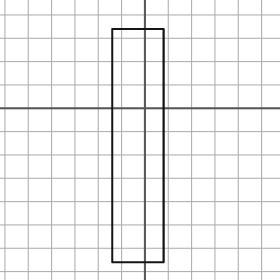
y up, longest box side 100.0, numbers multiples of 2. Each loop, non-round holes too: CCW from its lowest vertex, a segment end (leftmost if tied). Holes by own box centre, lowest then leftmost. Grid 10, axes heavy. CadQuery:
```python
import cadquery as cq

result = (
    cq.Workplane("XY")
    .moveTo(-14.0, -66.0)
    .lineTo(8.0, -66.0)
    .lineTo(8.0, 34.0)
    .lineTo(-14.0, 34.0)
    .close()
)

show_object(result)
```